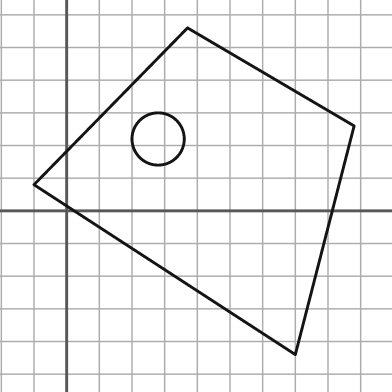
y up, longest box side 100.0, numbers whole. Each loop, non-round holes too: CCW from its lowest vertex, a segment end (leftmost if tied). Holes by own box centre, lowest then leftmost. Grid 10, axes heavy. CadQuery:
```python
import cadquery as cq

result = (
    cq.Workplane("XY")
    .moveTo(70.0, -44.0)
    .lineTo(88.0, 26.0)
    .lineTo(37.0, 56.0)
    .lineTo(-10.0, 8.0)
    .close()
    .moveTo(28.0, 22.0)
    .circle(8.0)
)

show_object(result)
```